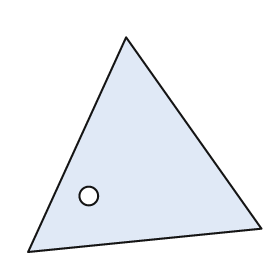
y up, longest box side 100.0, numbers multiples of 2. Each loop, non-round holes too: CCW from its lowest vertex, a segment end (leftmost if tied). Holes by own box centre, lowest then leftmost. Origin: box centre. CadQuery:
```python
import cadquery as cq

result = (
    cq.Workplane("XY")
    .moveTo(-50.0, -46.0)
    .lineTo(50.0, -36.0)
    .lineTo(-8.0, 46.0)
    .close()
    .moveTo(-24.0, -22.0)
    .circle(4.0)
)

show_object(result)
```